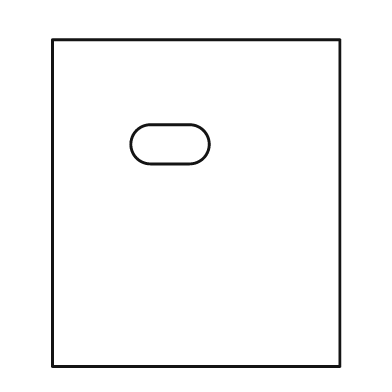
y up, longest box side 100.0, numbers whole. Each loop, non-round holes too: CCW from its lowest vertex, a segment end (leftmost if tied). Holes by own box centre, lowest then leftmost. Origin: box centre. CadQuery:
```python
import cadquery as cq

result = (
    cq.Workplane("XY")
    .moveTo(-44.0, -50.0)
    .lineTo(44.0, -50.0)
    .lineTo(44.0, 50.0)
    .lineTo(-44.0, 50.0)
    .close()
    .moveTo(-14.0, 12.0)
    .lineTo(-2.0, 12.0)
    .threePointArc((4.0, 18.0), (-2.0, 24.0))
    .lineTo(-14.0, 24.0)
    .threePointArc((-20.0, 18.0), (-14.0, 12.0))
    .close()
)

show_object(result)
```